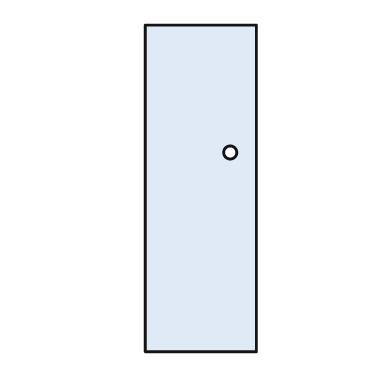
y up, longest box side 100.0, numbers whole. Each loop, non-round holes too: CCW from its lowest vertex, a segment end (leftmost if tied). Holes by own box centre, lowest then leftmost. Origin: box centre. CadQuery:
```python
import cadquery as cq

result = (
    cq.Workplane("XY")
    .moveTo(-17.0, -50.0)
    .lineTo(17.0, -50.0)
    .lineTo(17.0, 50.0)
    .lineTo(-17.0, 50.0)
    .close()
    .moveTo(9.0, 11.0)
    .circle(2.0)
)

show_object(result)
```